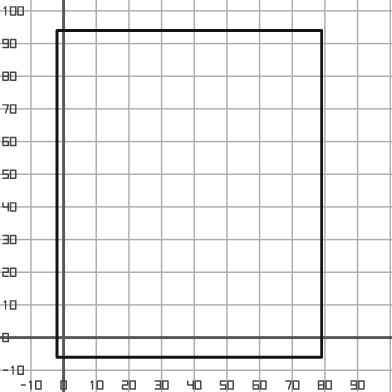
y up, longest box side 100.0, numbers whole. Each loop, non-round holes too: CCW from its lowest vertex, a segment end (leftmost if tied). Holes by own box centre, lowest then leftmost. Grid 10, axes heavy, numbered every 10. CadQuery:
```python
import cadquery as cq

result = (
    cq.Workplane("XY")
    .moveTo(-2.0, -6.0)
    .lineTo(79.0, -6.0)
    .lineTo(79.0, 94.0)
    .lineTo(-2.0, 94.0)
    .close()
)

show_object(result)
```